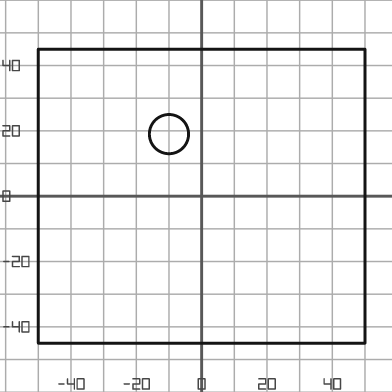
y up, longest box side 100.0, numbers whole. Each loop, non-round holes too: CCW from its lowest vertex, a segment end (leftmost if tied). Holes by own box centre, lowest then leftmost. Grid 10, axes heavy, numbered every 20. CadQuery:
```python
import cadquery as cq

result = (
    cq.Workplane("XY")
    .moveTo(-50.0, -45.0)
    .lineTo(50.0, -45.0)
    .lineTo(50.0, 45.0)
    .lineTo(-50.0, 45.0)
    .close()
    .moveTo(-10.0, 19.0)
    .circle(6.0)
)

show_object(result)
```